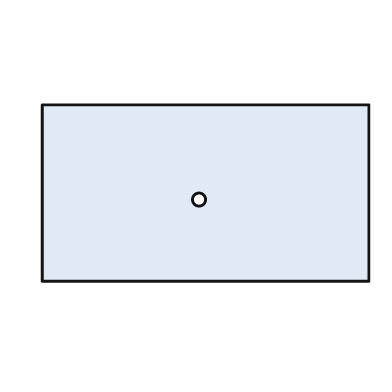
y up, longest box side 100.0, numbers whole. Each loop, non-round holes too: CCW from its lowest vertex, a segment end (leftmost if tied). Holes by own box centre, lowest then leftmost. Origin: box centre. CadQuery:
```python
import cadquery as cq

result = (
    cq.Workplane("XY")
    .moveTo(-50.0, -27.0)
    .lineTo(50.0, -27.0)
    .lineTo(50.0, 27.0)
    .lineTo(-50.0, 27.0)
    .close()
    .moveTo(-2.0, -2.0)
    .circle(2.0)
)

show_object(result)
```